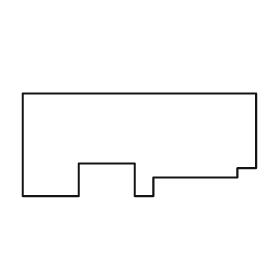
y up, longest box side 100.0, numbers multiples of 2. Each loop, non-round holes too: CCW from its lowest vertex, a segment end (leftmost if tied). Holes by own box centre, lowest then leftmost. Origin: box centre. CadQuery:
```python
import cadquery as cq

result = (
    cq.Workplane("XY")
    .moveTo(-50.0, -22.0)
    .lineTo(-26.0, -22.0)
    .lineTo(-26.0, -8.0)
    .lineTo(-2.0, -8.0)
    .lineTo(-2.0, -22.0)
    .lineTo(6.0, -22.0)
    .lineTo(6.0, -14.0)
    .lineTo(42.0, -14.0)
    .lineTo(42.0, -10.0)
    .lineTo(50.0, -10.0)
    .lineTo(50.0, 22.0)
    .lineTo(-50.0, 22.0)
    .close()
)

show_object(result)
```